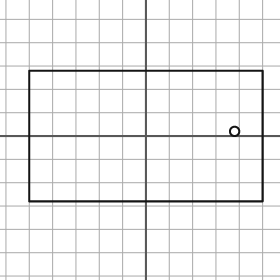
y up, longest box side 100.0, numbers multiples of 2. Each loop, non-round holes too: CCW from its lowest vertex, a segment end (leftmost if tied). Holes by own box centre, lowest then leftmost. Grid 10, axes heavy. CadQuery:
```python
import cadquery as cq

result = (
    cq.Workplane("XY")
    .moveTo(-50.0, -28.0)
    .lineTo(50.0, -28.0)
    .lineTo(50.0, 28.0)
    .lineTo(-50.0, 28.0)
    .close()
    .moveTo(38.0, 2.0)
    .circle(2.0)
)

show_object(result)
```